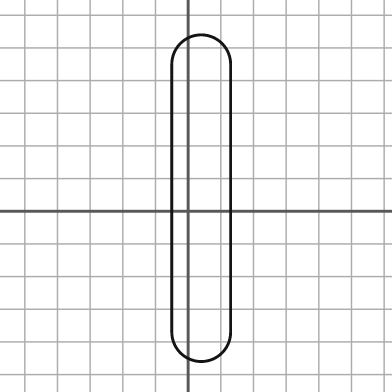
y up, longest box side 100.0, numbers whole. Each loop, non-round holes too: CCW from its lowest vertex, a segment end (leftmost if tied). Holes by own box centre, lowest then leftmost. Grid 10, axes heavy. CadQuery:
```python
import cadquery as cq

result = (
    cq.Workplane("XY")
    .moveTo(-5.0, -37.0)
    .threePointArc((4.0, -46.0), (13.0, -37.0))
    .lineTo(13.0, 45.0)
    .threePointArc((4.0, 54.0), (-5.0, 45.0))
    .close()
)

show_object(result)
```